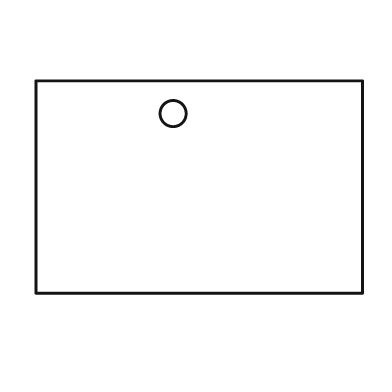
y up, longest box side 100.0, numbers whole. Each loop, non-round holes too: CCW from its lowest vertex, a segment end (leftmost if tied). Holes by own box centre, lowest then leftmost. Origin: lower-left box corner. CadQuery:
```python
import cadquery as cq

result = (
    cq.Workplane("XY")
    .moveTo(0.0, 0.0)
    .lineTo(100.0, 0.0)
    .lineTo(100.0, 65.0)
    .lineTo(0.0, 65.0)
    .close()
    .moveTo(42.0, 55.0)
    .circle(4.0)
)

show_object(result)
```